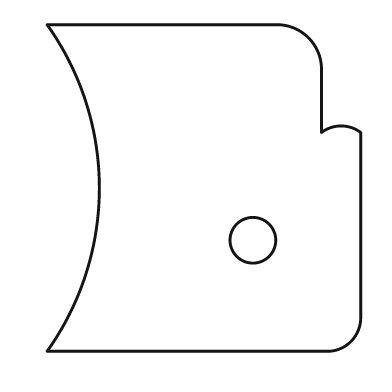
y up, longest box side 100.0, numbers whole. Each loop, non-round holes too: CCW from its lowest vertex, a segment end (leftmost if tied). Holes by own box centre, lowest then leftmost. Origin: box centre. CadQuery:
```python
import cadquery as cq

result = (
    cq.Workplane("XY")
    .moveTo(-48.0, -50.0)
    .lineTo(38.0, -50.0)
    .threePointArc((45.0, -47.0), (48.0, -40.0))
    .lineTo(48.0, 17.0)
    .threePointArc((42.0, 19.0), (36.0, 17.0))
    .lineTo(36.0, 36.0)
    .threePointArc((32.0, 46.0), (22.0, 50.0))
    .lineTo(-48.0, 50.0)
    .threePointArc((-32.0, 0.0), (-48.0, -50.0))
    .close()
    .moveTo(15.0, -16.0)
    .circle(7.0)
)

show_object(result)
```